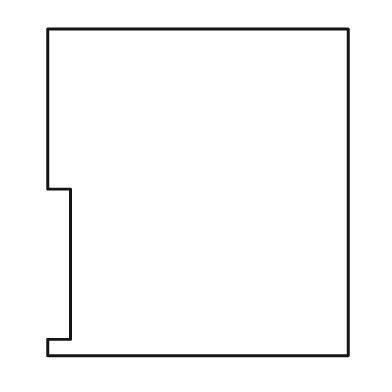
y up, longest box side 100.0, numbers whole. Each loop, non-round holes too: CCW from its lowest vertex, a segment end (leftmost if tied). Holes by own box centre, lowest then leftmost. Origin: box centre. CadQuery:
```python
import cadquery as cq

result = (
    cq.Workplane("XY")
    .moveTo(-46.0, -50.0)
    .lineTo(46.0, -50.0)
    .lineTo(46.0, 50.0)
    .lineTo(-46.0, 50.0)
    .lineTo(-46.0, 1.0)
    .lineTo(-39.0, 1.0)
    .lineTo(-39.0, -45.0)
    .lineTo(-46.0, -45.0)
    .close()
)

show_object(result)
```